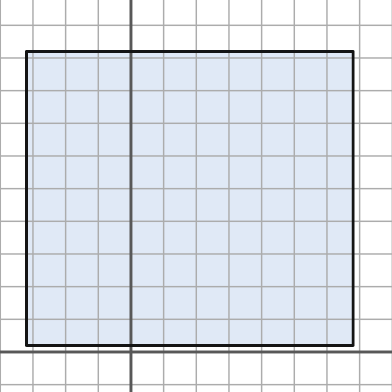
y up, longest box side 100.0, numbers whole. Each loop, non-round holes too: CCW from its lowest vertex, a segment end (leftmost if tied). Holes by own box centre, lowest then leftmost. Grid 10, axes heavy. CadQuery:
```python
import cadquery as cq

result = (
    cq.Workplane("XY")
    .moveTo(-32.0, 2.0)
    .lineTo(68.0, 2.0)
    .lineTo(68.0, 92.0)
    .lineTo(-32.0, 92.0)
    .close()
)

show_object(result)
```